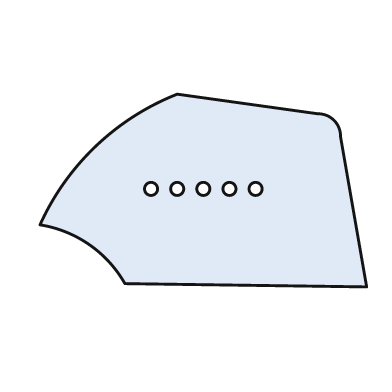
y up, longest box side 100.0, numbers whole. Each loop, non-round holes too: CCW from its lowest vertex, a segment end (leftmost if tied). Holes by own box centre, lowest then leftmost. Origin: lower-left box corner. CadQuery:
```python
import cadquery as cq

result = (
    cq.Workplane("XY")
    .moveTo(100.0, 0.0)
    .lineTo(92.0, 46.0)
    .threePointArc((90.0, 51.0), (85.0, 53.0))
    .lineTo(42.0, 59.0)
    .threePointArc((17.0, 43.0), (0.0, 19.0))
    .threePointArc((15.0, 13.0), (26.0, 1.0))
    .close()
    .moveTo(34.0, 30.0)
    .circle(2.0)
    .moveTo(42.0, 30.0)
    .circle(2.0)
    .moveTo(50.0, 30.0)
    .circle(2.0)
    .moveTo(58.0, 30.0)
    .circle(2.0)
    .moveTo(66.0, 30.0)
    .circle(2.0)
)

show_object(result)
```